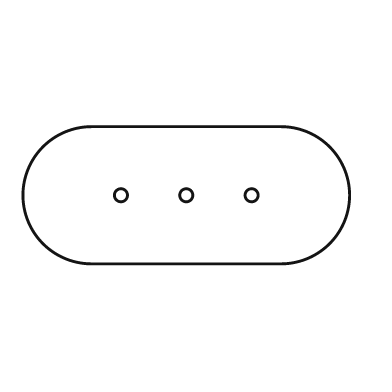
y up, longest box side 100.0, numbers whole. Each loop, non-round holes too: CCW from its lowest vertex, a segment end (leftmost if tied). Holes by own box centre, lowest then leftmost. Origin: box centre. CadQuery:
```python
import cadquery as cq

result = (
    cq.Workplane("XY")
    .moveTo(-29.0, -21.0)
    .lineTo(29.0, -21.0)
    .threePointArc((50.0, 0.0), (29.0, 21.0))
    .lineTo(-29.0, 21.0)
    .threePointArc((-50.0, 0.0), (-29.0, -21.0))
    .close()
    .moveTo(-20.0, 0.0)
    .circle(2.0)
    .moveTo(0.0, 0.0)
    .circle(2.0)
    .moveTo(20.0, 0.0)
    .circle(2.0)
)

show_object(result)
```